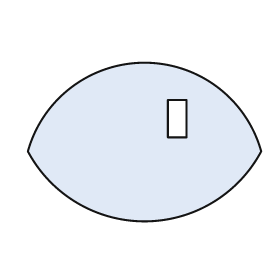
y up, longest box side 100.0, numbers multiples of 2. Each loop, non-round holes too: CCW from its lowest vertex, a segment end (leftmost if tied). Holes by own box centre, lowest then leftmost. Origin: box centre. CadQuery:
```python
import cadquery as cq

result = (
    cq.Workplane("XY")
    .moveTo(-50.0, -4.0)
    .threePointArc((0.0, -34.0), (50.0, -4.0))
    .threePointArc((0.0, 34.0), (-50.0, -4.0))
    .close()
    .moveTo(10.0, 2.0)
    .lineTo(18.0, 2.0)
    .lineTo(18.0, 18.0)
    .lineTo(10.0, 18.0)
    .close()
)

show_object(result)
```